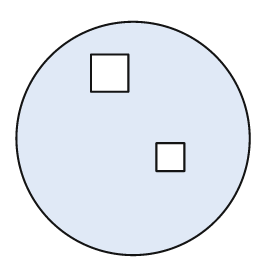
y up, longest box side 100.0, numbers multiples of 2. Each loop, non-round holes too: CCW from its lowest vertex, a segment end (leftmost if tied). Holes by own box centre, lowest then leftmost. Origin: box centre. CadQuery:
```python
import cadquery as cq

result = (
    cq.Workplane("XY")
    .moveTo(0.0, 0.0)
    .circle(50.0)
    .moveTo(10.0, -14.0)
    .lineTo(22.0, -14.0)
    .lineTo(22.0, -2.0)
    .lineTo(10.0, -2.0)
    .close()
    .moveTo(-18.0, 20.0)
    .lineTo(-2.0, 20.0)
    .lineTo(-2.0, 36.0)
    .lineTo(-18.0, 36.0)
    .close()
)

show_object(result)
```